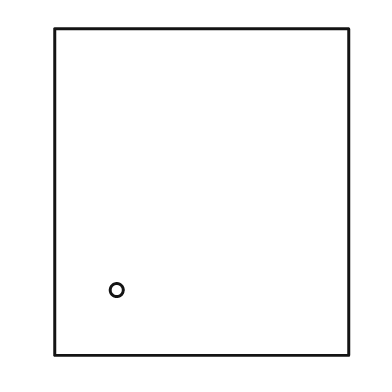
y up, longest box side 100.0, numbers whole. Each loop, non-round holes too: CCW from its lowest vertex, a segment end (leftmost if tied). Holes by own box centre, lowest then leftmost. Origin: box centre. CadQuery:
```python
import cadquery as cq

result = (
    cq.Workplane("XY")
    .moveTo(-45.0, -50.0)
    .lineTo(45.0, -50.0)
    .lineTo(45.0, 50.0)
    .lineTo(-45.0, 50.0)
    .close()
    .moveTo(-26.0, -30.0)
    .circle(2.0)
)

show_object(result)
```